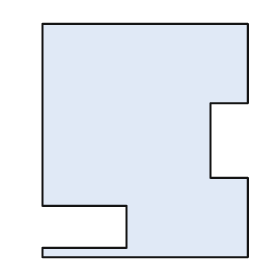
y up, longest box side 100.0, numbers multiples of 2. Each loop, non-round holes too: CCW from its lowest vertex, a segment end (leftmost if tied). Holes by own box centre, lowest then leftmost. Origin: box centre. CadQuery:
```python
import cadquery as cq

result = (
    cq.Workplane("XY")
    .moveTo(-44.0, -50.0)
    .lineTo(44.0, -50.0)
    .lineTo(44.0, -16.0)
    .lineTo(28.0, -16.0)
    .lineTo(28.0, 16.0)
    .lineTo(44.0, 16.0)
    .lineTo(44.0, 50.0)
    .lineTo(-44.0, 50.0)
    .lineTo(-44.0, -28.0)
    .lineTo(-8.0, -28.0)
    .lineTo(-8.0, -46.0)
    .lineTo(-44.0, -46.0)
    .close()
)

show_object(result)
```